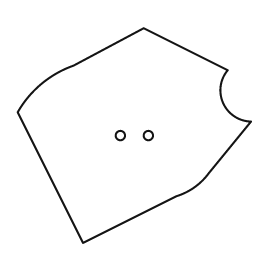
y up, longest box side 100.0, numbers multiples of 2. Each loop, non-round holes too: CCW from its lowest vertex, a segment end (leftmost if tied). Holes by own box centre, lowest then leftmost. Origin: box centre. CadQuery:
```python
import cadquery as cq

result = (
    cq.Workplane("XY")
    .moveTo(-22.0, -46.0)
    .lineTo(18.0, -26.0)
    .threePointArc((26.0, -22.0), (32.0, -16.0))
    .lineTo(50.0, 6.0)
    .threePointArc((38.0, 14.0), (40.0, 28.0))
    .lineTo(4.0, 46.0)
    .lineTo(-26.0, 30.0)
    .threePointArc((-40.0, 22.0), (-50.0, 10.0))
    .close()
    .moveTo(-6.0, 0.0)
    .circle(2.0)
    .moveTo(6.0, 0.0)
    .circle(2.0)
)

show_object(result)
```